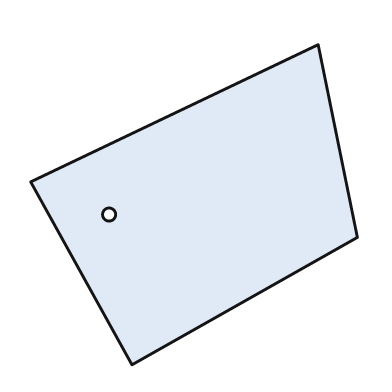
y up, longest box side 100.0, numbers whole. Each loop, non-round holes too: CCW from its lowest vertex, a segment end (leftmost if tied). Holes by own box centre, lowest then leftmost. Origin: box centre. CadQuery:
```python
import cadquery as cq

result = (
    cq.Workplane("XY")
    .moveTo(-19.0, -49.0)
    .lineTo(50.0, -10.0)
    .lineTo(38.0, 49.0)
    .lineTo(-50.0, 7.0)
    .close()
    .moveTo(-26.0, -3.0)
    .circle(2.0)
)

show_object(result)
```